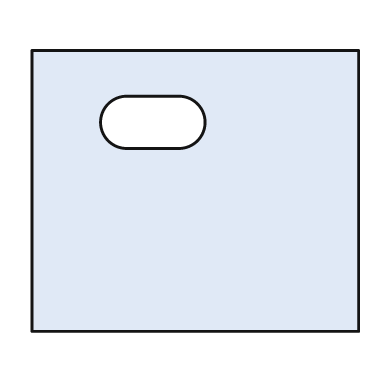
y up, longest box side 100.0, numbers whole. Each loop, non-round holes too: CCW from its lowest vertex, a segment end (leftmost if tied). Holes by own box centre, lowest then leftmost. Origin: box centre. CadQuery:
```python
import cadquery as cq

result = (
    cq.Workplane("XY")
    .moveTo(-50.0, -43.0)
    .lineTo(50.0, -43.0)
    .lineTo(50.0, 43.0)
    .lineTo(-50.0, 43.0)
    .close()
    .moveTo(-21.0, 13.0)
    .lineTo(-5.0, 13.0)
    .threePointArc((3.0, 21.0), (-5.0, 29.0))
    .lineTo(-21.0, 29.0)
    .threePointArc((-29.0, 21.0), (-21.0, 13.0))
    .close()
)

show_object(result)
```